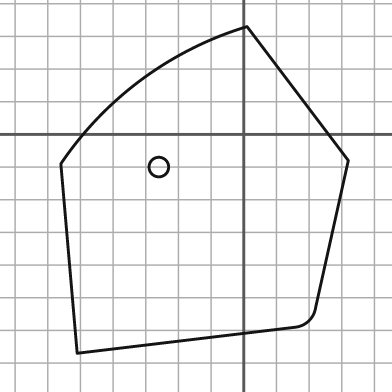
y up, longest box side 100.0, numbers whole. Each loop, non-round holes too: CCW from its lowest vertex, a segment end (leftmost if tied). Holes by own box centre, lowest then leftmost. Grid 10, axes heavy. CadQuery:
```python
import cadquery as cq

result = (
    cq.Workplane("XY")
    .moveTo(-51.0, -67.0)
    .lineTo(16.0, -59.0)
    .threePointArc((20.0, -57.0), (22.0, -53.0))
    .lineTo(32.0, -8.0)
    .lineTo(1.0, 33.0)
    .threePointArc((-31.0, 17.0), (-56.0, -9.0))
    .close()
    .moveTo(-26.0, -10.0)
    .circle(3.0)
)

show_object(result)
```